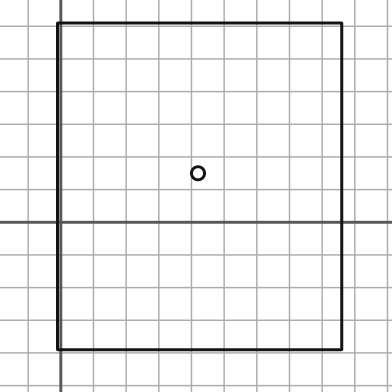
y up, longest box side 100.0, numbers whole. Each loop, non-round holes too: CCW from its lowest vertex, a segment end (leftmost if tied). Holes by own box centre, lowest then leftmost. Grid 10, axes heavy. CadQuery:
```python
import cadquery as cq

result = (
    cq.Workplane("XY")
    .moveTo(-1.0, -39.0)
    .lineTo(86.0, -39.0)
    .lineTo(86.0, 61.0)
    .lineTo(-1.0, 61.0)
    .close()
    .moveTo(42.0, 15.0)
    .circle(2.0)
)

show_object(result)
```